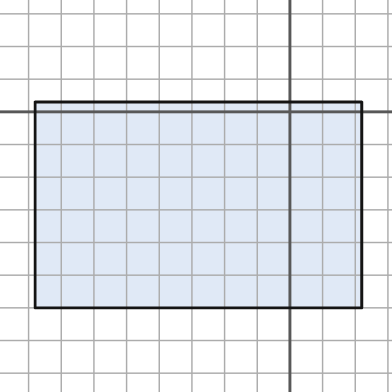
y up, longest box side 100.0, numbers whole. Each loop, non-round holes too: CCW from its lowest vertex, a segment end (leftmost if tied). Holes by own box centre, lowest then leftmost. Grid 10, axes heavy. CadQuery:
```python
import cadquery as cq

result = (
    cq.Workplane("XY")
    .moveTo(-78.0, -60.0)
    .lineTo(22.0, -60.0)
    .lineTo(22.0, 3.0)
    .lineTo(-78.0, 3.0)
    .close()
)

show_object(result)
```